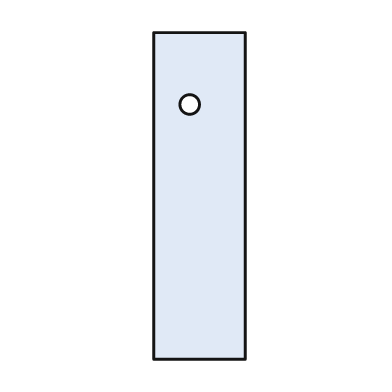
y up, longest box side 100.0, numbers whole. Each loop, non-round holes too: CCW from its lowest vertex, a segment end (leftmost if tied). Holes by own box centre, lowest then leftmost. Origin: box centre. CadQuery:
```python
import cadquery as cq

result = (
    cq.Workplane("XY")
    .moveTo(-14.0, -50.0)
    .lineTo(14.0, -50.0)
    .lineTo(14.0, 50.0)
    .lineTo(-14.0, 50.0)
    .close()
    .moveTo(-3.0, 28.0)
    .circle(3.0)
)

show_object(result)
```